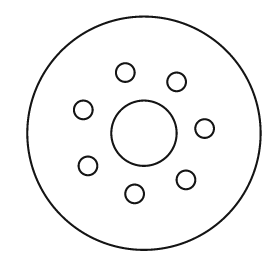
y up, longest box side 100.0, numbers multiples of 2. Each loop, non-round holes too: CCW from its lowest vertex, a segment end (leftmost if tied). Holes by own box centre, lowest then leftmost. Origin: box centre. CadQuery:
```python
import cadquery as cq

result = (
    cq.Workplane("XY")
    .moveTo(0.0, 0.0)
    .circle(50.0)
    .moveTo(-4.0, -26.0)
    .circle(4.0)
    .moveTo(18.0, -20.0)
    .circle(4.0)
    .moveTo(-24.0, -14.0)
    .circle(4.0)
    .moveTo(0.0, 0.0)
    .circle(14.0)
    .moveTo(26.0, 2.0)
    .circle(4.0)
    .moveTo(-26.0, 10.0)
    .circle(4.0)
    .moveTo(14.0, 22.0)
    .circle(4.0)
    .moveTo(-8.0, 26.0)
    .circle(4.0)
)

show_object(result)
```